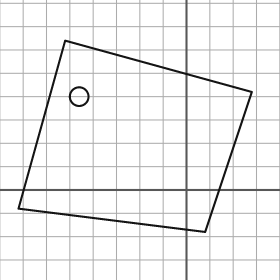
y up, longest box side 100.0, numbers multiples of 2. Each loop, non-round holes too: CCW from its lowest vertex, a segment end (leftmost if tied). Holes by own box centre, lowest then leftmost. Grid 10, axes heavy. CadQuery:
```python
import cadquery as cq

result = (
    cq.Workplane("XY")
    .moveTo(8.0, -18.0)
    .lineTo(28.0, 42.0)
    .lineTo(-52.0, 64.0)
    .lineTo(-72.0, -8.0)
    .close()
    .moveTo(-46.0, 40.0)
    .circle(4.0)
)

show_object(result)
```